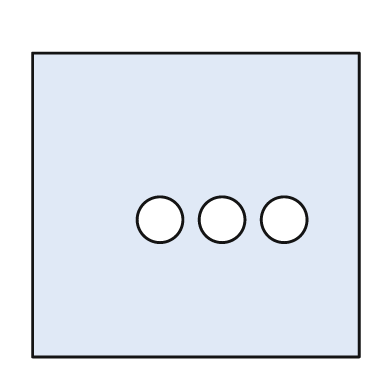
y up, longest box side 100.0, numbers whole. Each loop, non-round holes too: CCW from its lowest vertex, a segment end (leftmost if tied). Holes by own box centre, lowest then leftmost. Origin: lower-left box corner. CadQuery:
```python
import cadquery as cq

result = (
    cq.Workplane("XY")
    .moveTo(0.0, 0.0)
    .lineTo(100.0, 0.0)
    .lineTo(100.0, 93.0)
    .lineTo(0.0, 93.0)
    .close()
    .moveTo(39.0, 42.0)
    .circle(7.0)
    .moveTo(58.0, 42.0)
    .circle(7.0)
    .moveTo(77.0, 42.0)
    .circle(7.0)
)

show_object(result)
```